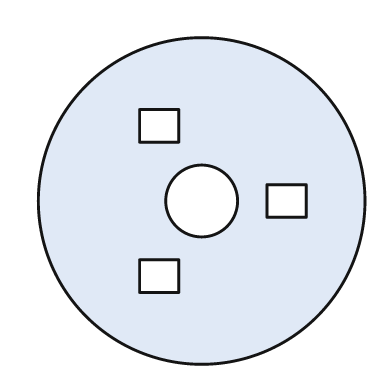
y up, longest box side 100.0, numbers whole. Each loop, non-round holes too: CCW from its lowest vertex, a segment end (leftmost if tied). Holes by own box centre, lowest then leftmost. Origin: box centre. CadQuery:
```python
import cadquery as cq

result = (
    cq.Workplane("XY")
    .moveTo(0.0, 0.0)
    .circle(50.0)
    .moveTo(-19.0, -28.0)
    .lineTo(-7.0, -28.0)
    .lineTo(-7.0, -18.0)
    .lineTo(-19.0, -18.0)
    .close()
    .moveTo(0.0, 0.0)
    .circle(11.0)
    .moveTo(20.0, -5.0)
    .lineTo(32.0, -5.0)
    .lineTo(32.0, 5.0)
    .lineTo(20.0, 5.0)
    .close()
    .moveTo(-19.0, 18.0)
    .lineTo(-7.0, 18.0)
    .lineTo(-7.0, 28.0)
    .lineTo(-19.0, 28.0)
    .close()
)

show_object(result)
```